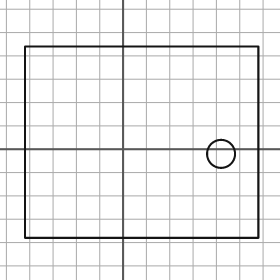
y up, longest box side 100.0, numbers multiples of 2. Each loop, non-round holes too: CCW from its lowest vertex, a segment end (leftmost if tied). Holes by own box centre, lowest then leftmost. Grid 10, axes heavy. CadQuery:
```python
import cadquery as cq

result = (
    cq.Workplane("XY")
    .moveTo(-42.0, -38.0)
    .lineTo(58.0, -38.0)
    .lineTo(58.0, 44.0)
    .lineTo(-42.0, 44.0)
    .close()
    .moveTo(42.0, -2.0)
    .circle(6.0)
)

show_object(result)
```